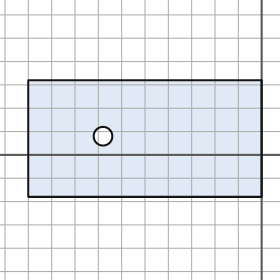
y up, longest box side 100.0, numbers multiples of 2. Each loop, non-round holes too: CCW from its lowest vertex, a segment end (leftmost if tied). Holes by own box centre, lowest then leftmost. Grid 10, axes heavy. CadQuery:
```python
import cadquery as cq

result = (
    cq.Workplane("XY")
    .moveTo(-100.0, -18.0)
    .lineTo(0.0, -18.0)
    .lineTo(0.0, 32.0)
    .lineTo(-100.0, 32.0)
    .close()
    .moveTo(-68.0, 8.0)
    .circle(4.0)
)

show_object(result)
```